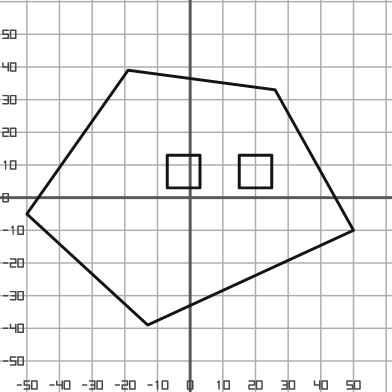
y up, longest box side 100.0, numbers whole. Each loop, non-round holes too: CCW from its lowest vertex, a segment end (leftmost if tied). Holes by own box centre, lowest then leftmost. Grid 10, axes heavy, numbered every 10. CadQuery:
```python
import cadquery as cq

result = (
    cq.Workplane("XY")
    .moveTo(-13.0, -39.0)
    .lineTo(50.0, -10.0)
    .lineTo(26.0, 33.0)
    .lineTo(-19.0, 39.0)
    .lineTo(-50.0, -5.0)
    .close()
    .moveTo(-7.0, 3.0)
    .lineTo(3.0, 3.0)
    .lineTo(3.0, 13.0)
    .lineTo(-7.0, 13.0)
    .close()
    .moveTo(15.0, 3.0)
    .lineTo(25.0, 3.0)
    .lineTo(25.0, 13.0)
    .lineTo(15.0, 13.0)
    .close()
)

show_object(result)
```